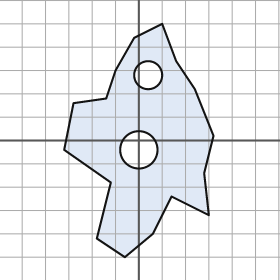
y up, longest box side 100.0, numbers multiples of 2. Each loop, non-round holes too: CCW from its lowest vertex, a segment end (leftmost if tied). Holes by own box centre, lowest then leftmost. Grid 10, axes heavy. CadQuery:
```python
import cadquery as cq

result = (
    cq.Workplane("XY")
    .moveTo(-6.0, -50.0)
    .lineTo(6.0, -40.0)
    .lineTo(14.0, -24.0)
    .lineTo(30.0, -32.0)
    .lineTo(28.0, -14.0)
    .lineTo(32.0, 2.0)
    .lineTo(24.0, 22.0)
    .lineTo(16.0, 34.0)
    .lineTo(10.0, 50.0)
    .lineTo(-2.0, 44.0)
    .lineTo(-10.0, 30.0)
    .lineTo(-14.0, 18.0)
    .lineTo(-28.0, 16.0)
    .lineTo(-32.0, -4.0)
    .lineTo(-12.0, -18.0)
    .lineTo(-18.0, -42.0)
    .close()
    .moveTo(0.0, -4.0)
    .circle(8.0)
    .moveTo(4.0, 28.0)
    .circle(6.0)
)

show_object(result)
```